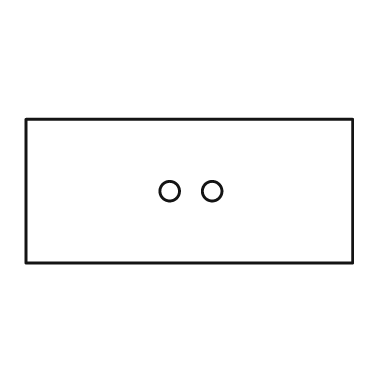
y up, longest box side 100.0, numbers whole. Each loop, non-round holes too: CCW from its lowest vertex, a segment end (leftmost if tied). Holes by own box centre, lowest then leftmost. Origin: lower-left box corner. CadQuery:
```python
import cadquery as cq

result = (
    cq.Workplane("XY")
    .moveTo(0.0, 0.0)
    .lineTo(100.0, 0.0)
    .lineTo(100.0, 44.0)
    .lineTo(0.0, 44.0)
    .close()
    .moveTo(44.0, 22.0)
    .circle(3.0)
    .moveTo(57.0, 22.0)
    .circle(3.0)
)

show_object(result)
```